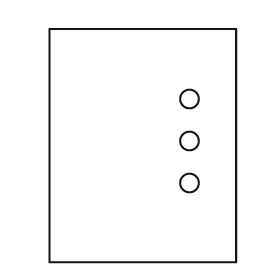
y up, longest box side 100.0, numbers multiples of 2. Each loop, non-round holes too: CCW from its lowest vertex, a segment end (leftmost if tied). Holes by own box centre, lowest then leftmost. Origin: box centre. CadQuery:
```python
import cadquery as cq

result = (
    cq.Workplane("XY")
    .moveTo(-40.0, -50.0)
    .lineTo(40.0, -50.0)
    .lineTo(40.0, 50.0)
    .lineTo(-40.0, 50.0)
    .close()
    .moveTo(20.0, -16.0)
    .circle(4.0)
    .moveTo(20.0, 2.0)
    .circle(4.0)
    .moveTo(20.0, 20.0)
    .circle(4.0)
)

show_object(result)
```